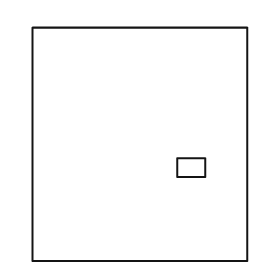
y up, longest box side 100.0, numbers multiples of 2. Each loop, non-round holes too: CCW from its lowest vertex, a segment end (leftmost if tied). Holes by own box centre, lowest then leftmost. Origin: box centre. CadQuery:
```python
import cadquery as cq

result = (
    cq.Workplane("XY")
    .moveTo(-46.0, -50.0)
    .lineTo(46.0, -50.0)
    .lineTo(46.0, 50.0)
    .lineTo(-46.0, 50.0)
    .close()
    .moveTo(16.0, -14.0)
    .lineTo(28.0, -14.0)
    .lineTo(28.0, -6.0)
    .lineTo(16.0, -6.0)
    .close()
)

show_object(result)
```